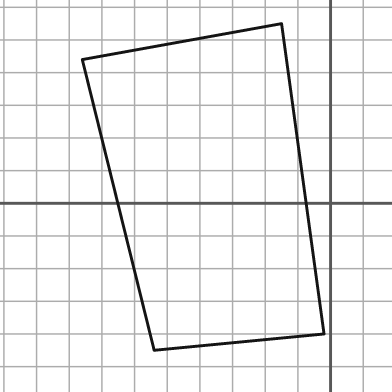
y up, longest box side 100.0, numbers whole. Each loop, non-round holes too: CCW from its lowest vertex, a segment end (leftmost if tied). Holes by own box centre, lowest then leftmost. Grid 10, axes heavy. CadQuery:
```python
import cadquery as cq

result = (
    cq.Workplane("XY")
    .moveTo(-54.0, -45.0)
    .lineTo(-2.0, -40.0)
    .lineTo(-15.0, 55.0)
    .lineTo(-76.0, 44.0)
    .close()
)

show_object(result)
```